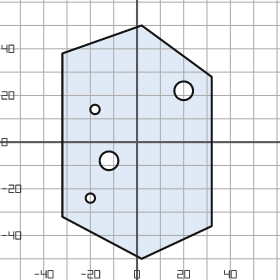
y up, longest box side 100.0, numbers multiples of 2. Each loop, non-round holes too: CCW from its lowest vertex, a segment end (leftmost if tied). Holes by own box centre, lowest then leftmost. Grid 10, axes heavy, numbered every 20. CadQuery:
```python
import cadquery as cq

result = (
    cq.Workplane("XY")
    .moveTo(2.0, -50.0)
    .lineTo(32.0, -36.0)
    .lineTo(32.0, 28.0)
    .lineTo(2.0, 50.0)
    .lineTo(-32.0, 38.0)
    .lineTo(-32.0, -32.0)
    .close()
    .moveTo(-20.0, -24.0)
    .circle(2.0)
    .moveTo(-12.0, -8.0)
    .circle(4.0)
    .moveTo(-18.0, 14.0)
    .circle(2.0)
    .moveTo(20.0, 22.0)
    .circle(4.0)
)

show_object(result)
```